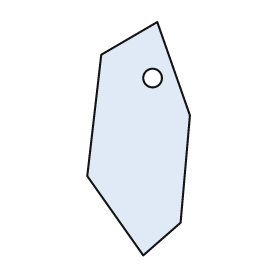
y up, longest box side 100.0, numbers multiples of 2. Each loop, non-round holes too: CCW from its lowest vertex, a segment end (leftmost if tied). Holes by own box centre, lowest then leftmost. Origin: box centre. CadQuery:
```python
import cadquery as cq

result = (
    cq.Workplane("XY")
    .moveTo(2.0, -50.0)
    .lineTo(18.0, -36.0)
    .lineTo(22.0, 10.0)
    .lineTo(8.0, 50.0)
    .lineTo(-16.0, 36.0)
    .lineTo(-22.0, -16.0)
    .close()
    .moveTo(6.0, 26.0)
    .circle(4.0)
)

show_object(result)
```